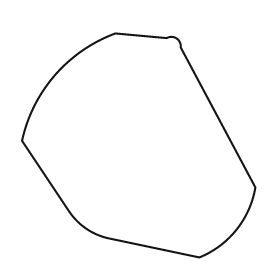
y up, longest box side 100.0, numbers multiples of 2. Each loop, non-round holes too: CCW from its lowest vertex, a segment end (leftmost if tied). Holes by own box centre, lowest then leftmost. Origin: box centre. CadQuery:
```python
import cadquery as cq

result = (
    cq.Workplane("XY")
    .moveTo(26.0, -48.0)
    .threePointArc((42.0, -36.0), (50.0, -18.0))
    .lineTo(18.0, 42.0)
    .threePointArc((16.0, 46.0), (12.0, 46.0))
    .lineTo(-10.0, 48.0)
    .threePointArc((-36.0, 30.0), (-50.0, 2.0))
    .lineTo(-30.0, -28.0)
    .threePointArc((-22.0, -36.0), (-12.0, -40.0))
    .close()
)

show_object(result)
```